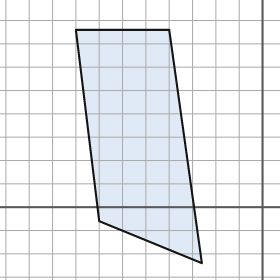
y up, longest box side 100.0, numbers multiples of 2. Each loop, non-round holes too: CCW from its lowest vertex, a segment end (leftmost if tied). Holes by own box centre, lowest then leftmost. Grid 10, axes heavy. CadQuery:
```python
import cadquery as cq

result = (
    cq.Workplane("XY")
    .moveTo(-26.0, -24.0)
    .lineTo(-40.0, 76.0)
    .lineTo(-80.0, 76.0)
    .lineTo(-70.0, -6.0)
    .close()
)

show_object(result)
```